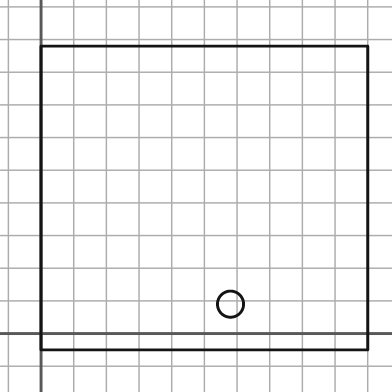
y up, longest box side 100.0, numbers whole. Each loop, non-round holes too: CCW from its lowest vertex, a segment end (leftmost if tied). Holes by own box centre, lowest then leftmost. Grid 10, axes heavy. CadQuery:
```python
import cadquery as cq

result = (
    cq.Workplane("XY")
    .moveTo(0.0, -5.0)
    .lineTo(100.0, -5.0)
    .lineTo(100.0, 88.0)
    .lineTo(0.0, 88.0)
    .close()
    .moveTo(58.0, 9.0)
    .circle(4.0)
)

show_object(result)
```